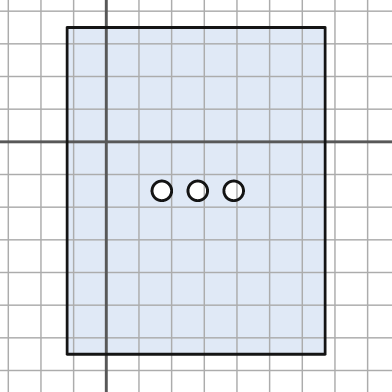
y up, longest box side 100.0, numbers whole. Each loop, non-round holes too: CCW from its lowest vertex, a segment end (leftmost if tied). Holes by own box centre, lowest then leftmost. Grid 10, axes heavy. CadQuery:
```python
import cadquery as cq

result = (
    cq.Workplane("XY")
    .moveTo(-12.0, -65.0)
    .lineTo(67.0, -65.0)
    .lineTo(67.0, 35.0)
    .lineTo(-12.0, 35.0)
    .close()
    .moveTo(17.0, -15.0)
    .circle(3.0)
    .moveTo(28.0, -15.0)
    .circle(3.0)
    .moveTo(39.0, -15.0)
    .circle(3.0)
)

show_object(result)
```